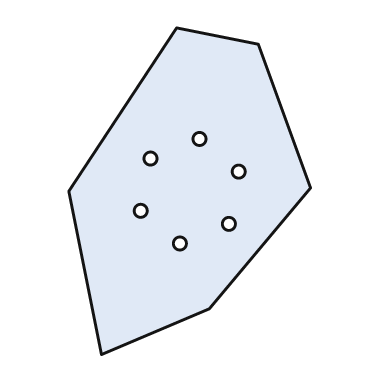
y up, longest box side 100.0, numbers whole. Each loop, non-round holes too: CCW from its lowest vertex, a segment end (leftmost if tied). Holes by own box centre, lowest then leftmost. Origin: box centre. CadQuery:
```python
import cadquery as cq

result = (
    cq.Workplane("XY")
    .moveTo(-27.0, -50.0)
    .lineTo(6.0, -36.0)
    .lineTo(37.0, 1.0)
    .lineTo(21.0, 45.0)
    .lineTo(-4.0, 50.0)
    .lineTo(-37.0, 0.0)
    .close()
    .moveTo(-3.0, -16.0)
    .circle(2.0)
    .moveTo(12.0, -10.0)
    .circle(2.0)
    .moveTo(-15.0, -6.0)
    .circle(2.0)
    .moveTo(15.0, 6.0)
    .circle(2.0)
    .moveTo(-12.0, 10.0)
    .circle(2.0)
    .moveTo(3.0, 16.0)
    .circle(2.0)
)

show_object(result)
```